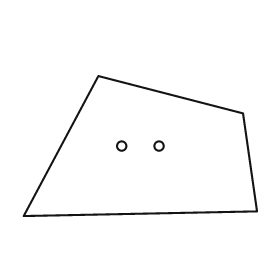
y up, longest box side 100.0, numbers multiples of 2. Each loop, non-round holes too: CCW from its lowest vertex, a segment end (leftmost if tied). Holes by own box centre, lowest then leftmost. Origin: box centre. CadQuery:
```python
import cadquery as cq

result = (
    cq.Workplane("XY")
    .moveTo(-50.0, -30.0)
    .lineTo(50.0, -28.0)
    .lineTo(44.0, 14.0)
    .lineTo(-18.0, 30.0)
    .close()
    .moveTo(-8.0, 0.0)
    .circle(2.0)
    .moveTo(8.0, 0.0)
    .circle(2.0)
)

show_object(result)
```